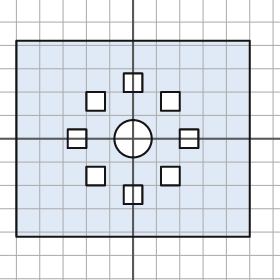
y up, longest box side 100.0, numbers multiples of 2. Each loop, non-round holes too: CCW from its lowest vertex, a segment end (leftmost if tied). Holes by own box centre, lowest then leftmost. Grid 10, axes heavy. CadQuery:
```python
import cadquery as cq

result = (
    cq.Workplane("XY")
    .moveTo(-50.0, -42.0)
    .lineTo(50.0, -42.0)
    .lineTo(50.0, 42.0)
    .lineTo(-50.0, 42.0)
    .close()
    .moveTo(-4.0, -28.0)
    .lineTo(4.0, -28.0)
    .lineTo(4.0, -20.0)
    .lineTo(-4.0, -20.0)
    .close()
    .moveTo(-20.0, -20.0)
    .lineTo(-12.0, -20.0)
    .lineTo(-12.0, -12.0)
    .lineTo(-20.0, -12.0)
    .close()
    .moveTo(12.0, -20.0)
    .lineTo(20.0, -20.0)
    .lineTo(20.0, -12.0)
    .lineTo(12.0, -12.0)
    .close()
    .moveTo(-28.0, -4.0)
    .lineTo(-20.0, -4.0)
    .lineTo(-20.0, 4.0)
    .lineTo(-28.0, 4.0)
    .close()
    .moveTo(0.0, 0.0)
    .circle(8.0)
    .moveTo(20.0, -4.0)
    .lineTo(28.0, -4.0)
    .lineTo(28.0, 4.0)
    .lineTo(20.0, 4.0)
    .close()
    .moveTo(-20.0, 12.0)
    .lineTo(-12.0, 12.0)
    .lineTo(-12.0, 20.0)
    .lineTo(-20.0, 20.0)
    .close()
    .moveTo(12.0, 12.0)
    .lineTo(20.0, 12.0)
    .lineTo(20.0, 20.0)
    .lineTo(12.0, 20.0)
    .close()
    .moveTo(-4.0, 20.0)
    .lineTo(4.0, 20.0)
    .lineTo(4.0, 28.0)
    .lineTo(-4.0, 28.0)
    .close()
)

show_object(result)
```